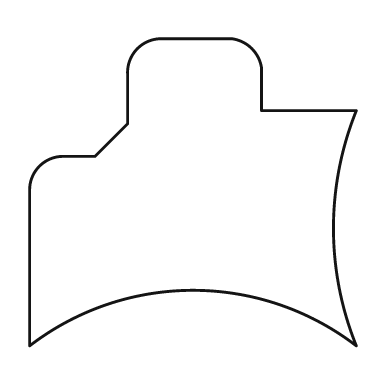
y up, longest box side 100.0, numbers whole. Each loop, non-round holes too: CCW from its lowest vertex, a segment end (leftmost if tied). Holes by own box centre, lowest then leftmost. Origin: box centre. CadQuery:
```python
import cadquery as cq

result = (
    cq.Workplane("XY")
    .moveTo(-50.0, -47.0)
    .threePointArc((0.0, -30.0), (50.0, -47.0))
    .threePointArc((43.0, -11.0), (50.0, 25.0))
    .lineTo(21.0, 25.0)
    .lineTo(21.0, 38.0)
    .threePointArc((18.0, 44.0), (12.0, 47.0))
    .lineTo(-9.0, 47.0)
    .threePointArc((-17.0, 44.0), (-20.0, 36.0))
    .lineTo(-20.0, 21.0)
    .lineTo(-30.0, 11.0)
    .lineTo(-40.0, 11.0)
    .threePointArc((-47.0, 8.0), (-50.0, 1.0))
    .close()
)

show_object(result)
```